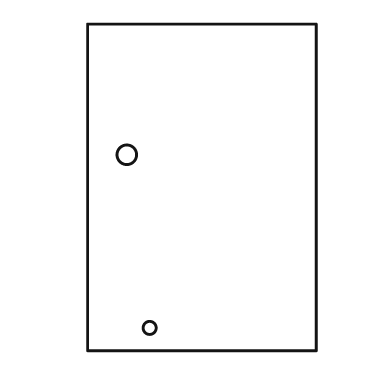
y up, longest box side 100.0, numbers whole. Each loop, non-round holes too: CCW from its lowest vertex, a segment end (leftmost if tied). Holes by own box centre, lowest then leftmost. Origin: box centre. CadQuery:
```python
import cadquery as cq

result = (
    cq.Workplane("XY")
    .moveTo(-35.0, -50.0)
    .lineTo(35.0, -50.0)
    .lineTo(35.0, 50.0)
    .lineTo(-35.0, 50.0)
    .close()
    .moveTo(-16.0, -43.0)
    .circle(2.0)
    .moveTo(-23.0, 10.0)
    .circle(3.0)
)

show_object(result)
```